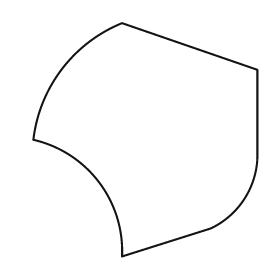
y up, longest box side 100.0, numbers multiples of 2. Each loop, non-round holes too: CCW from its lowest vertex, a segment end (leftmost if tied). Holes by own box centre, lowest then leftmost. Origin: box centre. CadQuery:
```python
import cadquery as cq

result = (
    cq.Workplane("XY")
    .moveTo(-10.0, -50.0)
    .lineTo(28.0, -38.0)
    .threePointArc((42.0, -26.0), (48.0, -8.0))
    .lineTo(48.0, 30.0)
    .lineTo(-10.0, 50.0)
    .threePointArc((-36.0, 30.0), (-48.0, 0.0))
    .threePointArc((-20.0, -18.0), (-10.0, -50.0))
    .close()
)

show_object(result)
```